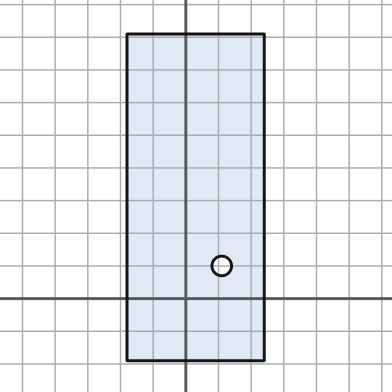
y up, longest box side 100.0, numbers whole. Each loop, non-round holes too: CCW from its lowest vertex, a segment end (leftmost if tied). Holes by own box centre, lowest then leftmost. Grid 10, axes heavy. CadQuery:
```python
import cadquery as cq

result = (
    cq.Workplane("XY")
    .moveTo(-18.0, -19.0)
    .lineTo(24.0, -19.0)
    .lineTo(24.0, 81.0)
    .lineTo(-18.0, 81.0)
    .close()
    .moveTo(11.0, 10.0)
    .circle(3.0)
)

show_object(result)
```